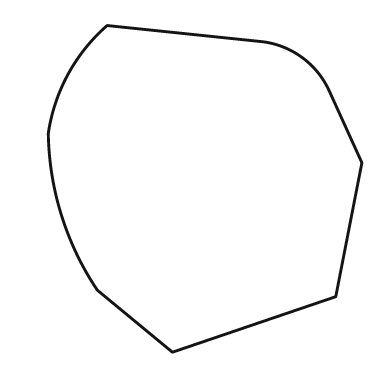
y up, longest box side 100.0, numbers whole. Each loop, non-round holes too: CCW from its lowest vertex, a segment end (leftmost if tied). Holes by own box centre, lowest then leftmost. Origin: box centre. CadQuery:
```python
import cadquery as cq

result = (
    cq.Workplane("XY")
    .moveTo(-10.0, -50.0)
    .lineTo(40.0, -33.0)
    .lineTo(48.0, 8.0)
    .lineTo(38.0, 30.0)
    .threePointArc((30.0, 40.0), (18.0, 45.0))
    .lineTo(-30.0, 50.0)
    .threePointArc((-42.0, 35.0), (-48.0, 17.0))
    .threePointArc((-44.0, -8.0), (-33.0, -31.0))
    .close()
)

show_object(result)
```